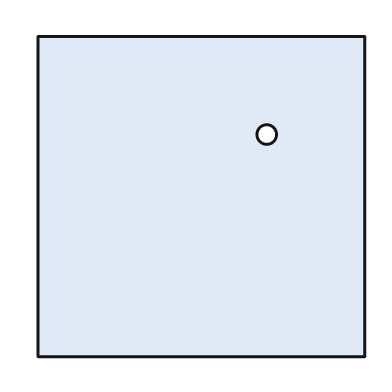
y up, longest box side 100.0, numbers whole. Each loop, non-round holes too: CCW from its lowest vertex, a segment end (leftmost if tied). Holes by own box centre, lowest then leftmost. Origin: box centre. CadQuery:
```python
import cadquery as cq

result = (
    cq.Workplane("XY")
    .moveTo(-50.0, -49.0)
    .lineTo(50.0, -49.0)
    .lineTo(50.0, 49.0)
    .lineTo(-50.0, 49.0)
    .close()
    .moveTo(20.0, 19.0)
    .circle(3.0)
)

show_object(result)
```